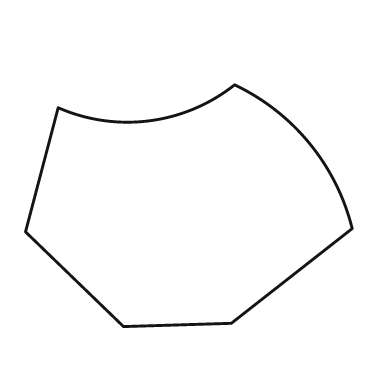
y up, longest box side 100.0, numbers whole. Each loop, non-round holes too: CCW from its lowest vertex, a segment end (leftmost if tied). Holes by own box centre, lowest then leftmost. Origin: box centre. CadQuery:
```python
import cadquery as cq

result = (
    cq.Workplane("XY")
    .moveTo(-20.0, -37.0)
    .lineTo(13.0, -36.0)
    .lineTo(50.0, -7.0)
    .threePointArc((37.0, 19.0), (14.0, 37.0))
    .threePointArc((-12.0, 26.0), (-40.0, 30.0))
    .lineTo(-50.0, -8.0)
    .close()
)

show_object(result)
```